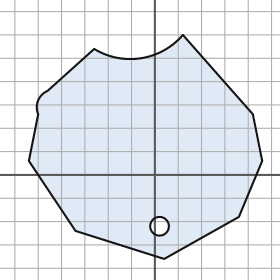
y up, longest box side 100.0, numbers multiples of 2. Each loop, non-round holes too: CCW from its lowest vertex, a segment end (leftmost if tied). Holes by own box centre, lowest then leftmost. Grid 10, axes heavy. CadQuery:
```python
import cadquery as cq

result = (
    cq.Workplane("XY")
    .moveTo(4.0, -36.0)
    .lineTo(36.0, -18.0)
    .lineTo(46.0, 6.0)
    .lineTo(42.0, 26.0)
    .lineTo(12.0, 60.0)
    .threePointArc((-6.0, 50.0), (-26.0, 54.0))
    .lineTo(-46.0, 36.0)
    .threePointArc((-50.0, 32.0), (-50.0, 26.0))
    .lineTo(-54.0, 6.0)
    .lineTo(-34.0, -24.0)
    .close()
    .moveTo(2.0, -22.0)
    .circle(4.0)
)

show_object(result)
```